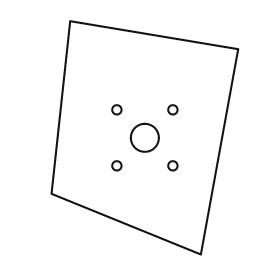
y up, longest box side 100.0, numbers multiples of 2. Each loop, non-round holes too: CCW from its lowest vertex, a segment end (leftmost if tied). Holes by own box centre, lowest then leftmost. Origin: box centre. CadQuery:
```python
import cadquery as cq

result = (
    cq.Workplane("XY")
    .moveTo(24.0, -50.0)
    .lineTo(40.0, 38.0)
    .lineTo(-32.0, 50.0)
    .lineTo(-40.0, -24.0)
    .close()
    .moveTo(-12.0, -12.0)
    .circle(2.0)
    .moveTo(12.0, -12.0)
    .circle(2.0)
    .moveTo(0.0, 0.0)
    .circle(6.0)
    .moveTo(-12.0, 12.0)
    .circle(2.0)
    .moveTo(12.0, 12.0)
    .circle(2.0)
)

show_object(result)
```